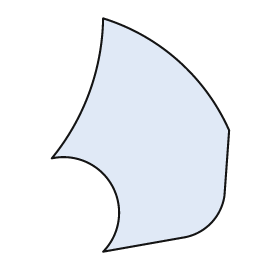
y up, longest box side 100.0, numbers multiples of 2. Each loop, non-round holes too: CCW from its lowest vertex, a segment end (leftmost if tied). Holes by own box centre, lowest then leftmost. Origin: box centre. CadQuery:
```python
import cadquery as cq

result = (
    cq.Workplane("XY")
    .moveTo(-16.0, -50.0)
    .lineTo(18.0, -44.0)
    .threePointArc((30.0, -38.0), (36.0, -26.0))
    .lineTo(38.0, 2.0)
    .threePointArc((16.0, 32.0), (-16.0, 50.0))
    .threePointArc((-22.0, 18.0), (-38.0, -10.0))
    .threePointArc((-12.0, -22.0), (-16.0, -50.0))
    .close()
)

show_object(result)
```